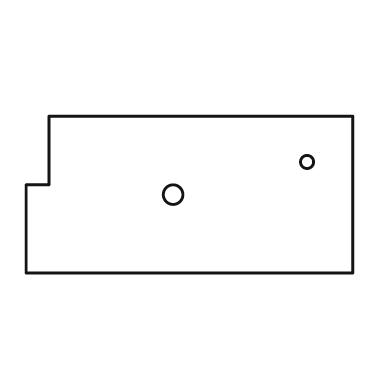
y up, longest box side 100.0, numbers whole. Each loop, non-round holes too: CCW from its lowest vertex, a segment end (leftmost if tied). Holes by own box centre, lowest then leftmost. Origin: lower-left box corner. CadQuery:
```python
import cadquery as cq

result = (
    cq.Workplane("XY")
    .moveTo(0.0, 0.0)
    .lineTo(100.0, 0.0)
    .lineTo(100.0, 48.0)
    .lineTo(7.0, 48.0)
    .lineTo(7.0, 27.0)
    .lineTo(0.0, 27.0)
    .close()
    .moveTo(45.0, 24.0)
    .circle(3.0)
    .moveTo(86.0, 34.0)
    .circle(2.0)
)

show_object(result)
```